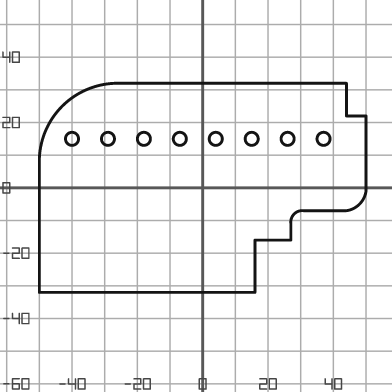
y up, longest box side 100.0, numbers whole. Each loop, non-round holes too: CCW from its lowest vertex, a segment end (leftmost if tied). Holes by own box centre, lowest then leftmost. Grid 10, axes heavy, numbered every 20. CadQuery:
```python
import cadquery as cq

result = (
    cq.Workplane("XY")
    .moveTo(-50.0, -32.0)
    .lineTo(16.0, -32.0)
    .lineTo(16.0, -16.0)
    .lineTo(27.0, -16.0)
    .lineTo(27.0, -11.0)
    .threePointArc((28.0, -8.0), (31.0, -7.0))
    .lineTo(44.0, -7.0)
    .threePointArc((48.0, -5.0), (50.0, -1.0))
    .lineTo(50.0, 22.0)
    .lineTo(44.0, 22.0)
    .lineTo(44.0, 32.0)
    .lineTo(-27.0, 32.0)
    .threePointArc((-43.0, 25.0), (-50.0, 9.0))
    .close()
    .moveTo(-40.0, 15.0)
    .circle(2.0)
    .moveTo(-29.0, 15.0)
    .circle(2.0)
    .moveTo(-18.0, 15.0)
    .circle(2.0)
    .moveTo(-7.0, 15.0)
    .circle(2.0)
    .moveTo(4.0, 15.0)
    .circle(2.0)
    .moveTo(15.0, 15.0)
    .circle(2.0)
    .moveTo(26.0, 15.0)
    .circle(2.0)
    .moveTo(37.0, 15.0)
    .circle(2.0)
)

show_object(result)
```